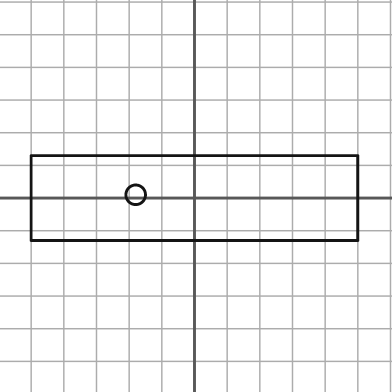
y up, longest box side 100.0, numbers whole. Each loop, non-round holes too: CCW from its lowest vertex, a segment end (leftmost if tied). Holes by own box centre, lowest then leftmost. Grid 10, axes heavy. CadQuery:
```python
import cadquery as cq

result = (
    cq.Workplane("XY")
    .moveTo(-50.0, -13.0)
    .lineTo(50.0, -13.0)
    .lineTo(50.0, 13.0)
    .lineTo(-50.0, 13.0)
    .close()
    .moveTo(-18.0, 1.0)
    .circle(3.0)
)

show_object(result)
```